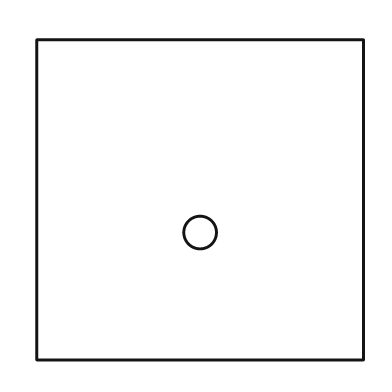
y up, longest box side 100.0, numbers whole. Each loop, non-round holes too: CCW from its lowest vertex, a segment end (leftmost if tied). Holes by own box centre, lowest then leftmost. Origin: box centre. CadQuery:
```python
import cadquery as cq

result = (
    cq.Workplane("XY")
    .moveTo(-50.0, -49.0)
    .lineTo(50.0, -49.0)
    .lineTo(50.0, 49.0)
    .lineTo(-50.0, 49.0)
    .close()
    .moveTo(0.0, -10.0)
    .circle(5.0)
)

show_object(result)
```